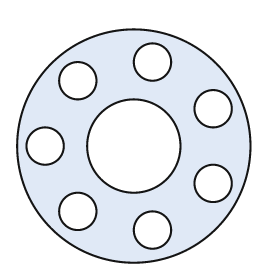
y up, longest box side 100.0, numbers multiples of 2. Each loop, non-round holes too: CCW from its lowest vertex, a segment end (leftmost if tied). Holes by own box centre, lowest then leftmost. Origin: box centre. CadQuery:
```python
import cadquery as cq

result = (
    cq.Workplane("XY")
    .moveTo(0.0, 0.0)
    .circle(50.0)
    .moveTo(8.0, -36.0)
    .circle(8.0)
    .moveTo(-24.0, -28.0)
    .circle(8.0)
    .moveTo(34.0, -16.0)
    .circle(8.0)
    .moveTo(-38.0, 0.0)
    .circle(8.0)
    .moveTo(0.0, 0.0)
    .circle(20.0)
    .moveTo(34.0, 16.0)
    .circle(8.0)
    .moveTo(-24.0, 28.0)
    .circle(8.0)
    .moveTo(8.0, 36.0)
    .circle(8.0)
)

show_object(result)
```